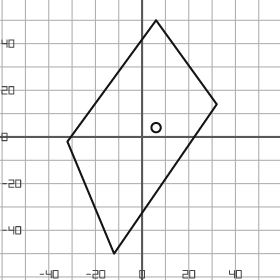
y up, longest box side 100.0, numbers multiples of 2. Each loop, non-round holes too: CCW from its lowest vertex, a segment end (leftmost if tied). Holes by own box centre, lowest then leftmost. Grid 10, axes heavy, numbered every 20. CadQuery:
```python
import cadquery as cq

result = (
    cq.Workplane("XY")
    .moveTo(-12.0, -50.0)
    .lineTo(32.0, 14.0)
    .lineTo(6.0, 50.0)
    .lineTo(-32.0, -2.0)
    .close()
    .moveTo(6.0, 4.0)
    .circle(2.0)
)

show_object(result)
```